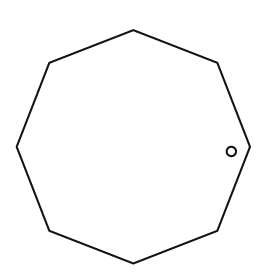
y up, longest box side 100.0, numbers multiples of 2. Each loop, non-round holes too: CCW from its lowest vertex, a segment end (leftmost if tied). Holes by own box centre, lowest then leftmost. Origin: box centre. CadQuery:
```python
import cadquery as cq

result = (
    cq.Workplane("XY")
    .moveTo(0.0, -50.0)
    .lineTo(36.0, -36.0)
    .lineTo(50.0, 0.0)
    .lineTo(36.0, 36.0)
    .lineTo(0.0, 50.0)
    .lineTo(-36.0, 36.0)
    .lineTo(-50.0, 0.0)
    .lineTo(-36.0, -36.0)
    .close()
    .moveTo(42.0, -2.0)
    .circle(2.0)
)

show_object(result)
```